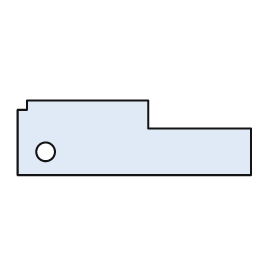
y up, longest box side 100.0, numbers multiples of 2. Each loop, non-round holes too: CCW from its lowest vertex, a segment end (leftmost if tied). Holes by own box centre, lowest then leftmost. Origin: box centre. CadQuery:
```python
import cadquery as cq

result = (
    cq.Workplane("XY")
    .moveTo(-50.0, -16.0)
    .lineTo(50.0, -16.0)
    .lineTo(50.0, 4.0)
    .lineTo(6.0, 4.0)
    .lineTo(6.0, 16.0)
    .lineTo(-46.0, 16.0)
    .lineTo(-46.0, 12.0)
    .lineTo(-50.0, 12.0)
    .close()
    .moveTo(-38.0, -6.0)
    .circle(4.0)
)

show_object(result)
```